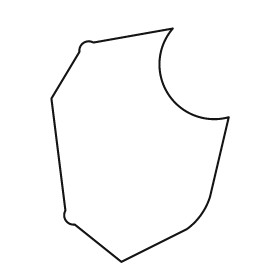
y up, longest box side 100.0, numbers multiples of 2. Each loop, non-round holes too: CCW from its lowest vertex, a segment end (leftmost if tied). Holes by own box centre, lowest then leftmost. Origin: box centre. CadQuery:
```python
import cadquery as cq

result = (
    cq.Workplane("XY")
    .moveTo(-8.0, -50.0)
    .lineTo(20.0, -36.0)
    .threePointArc((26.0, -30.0), (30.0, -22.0))
    .lineTo(38.0, 12.0)
    .threePointArc((12.0, 22.0), (14.0, 50.0))
    .lineTo(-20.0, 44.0)
    .threePointArc((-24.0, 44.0), (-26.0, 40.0))
    .lineTo(-38.0, 20.0)
    .lineTo(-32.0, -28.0)
    .threePointArc((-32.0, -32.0), (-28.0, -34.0))
    .close()
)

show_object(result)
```